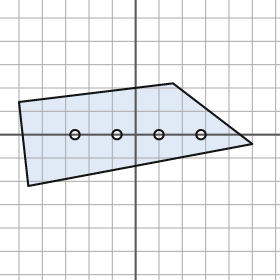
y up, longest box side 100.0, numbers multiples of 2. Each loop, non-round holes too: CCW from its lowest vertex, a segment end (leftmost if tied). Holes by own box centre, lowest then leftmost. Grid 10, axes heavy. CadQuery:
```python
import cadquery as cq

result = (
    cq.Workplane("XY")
    .moveTo(-46.0, -22.0)
    .lineTo(50.0, -4.0)
    .lineTo(16.0, 22.0)
    .lineTo(-50.0, 14.0)
    .close()
    .moveTo(-26.0, 0.0)
    .circle(2.0)
    .moveTo(-8.0, 0.0)
    .circle(2.0)
    .moveTo(10.0, 0.0)
    .circle(2.0)
    .moveTo(28.0, 0.0)
    .circle(2.0)
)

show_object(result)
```